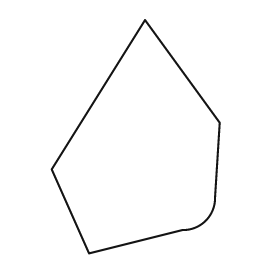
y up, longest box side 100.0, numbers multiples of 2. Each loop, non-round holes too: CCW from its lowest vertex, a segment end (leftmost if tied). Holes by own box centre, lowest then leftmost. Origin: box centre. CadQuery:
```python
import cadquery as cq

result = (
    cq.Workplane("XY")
    .moveTo(-20.0, -50.0)
    .lineTo(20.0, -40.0)
    .threePointArc((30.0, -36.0), (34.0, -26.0))
    .lineTo(36.0, 6.0)
    .lineTo(4.0, 50.0)
    .lineTo(-36.0, -14.0)
    .close()
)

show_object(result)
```